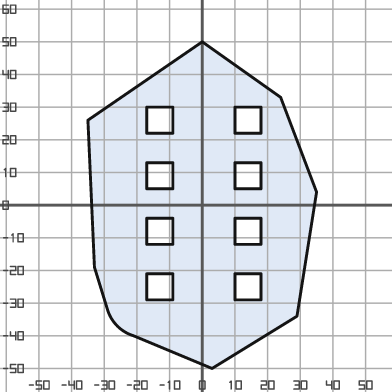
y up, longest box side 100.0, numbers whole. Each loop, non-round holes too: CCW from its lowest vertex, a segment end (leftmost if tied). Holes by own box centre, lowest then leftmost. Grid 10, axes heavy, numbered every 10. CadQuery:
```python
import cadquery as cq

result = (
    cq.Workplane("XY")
    .moveTo(3.0, -50.0)
    .lineTo(29.0, -34.0)
    .lineTo(35.0, 4.0)
    .lineTo(24.0, 33.0)
    .lineTo(0.0, 50.0)
    .lineTo(-35.0, 26.0)
    .lineTo(-33.0, -19.0)
    .lineTo(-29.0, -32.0)
    .threePointArc((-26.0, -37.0), (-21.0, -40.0))
    .close()
    .moveTo(-17.0, -29.0)
    .lineTo(-9.0, -29.0)
    .lineTo(-9.0, -21.0)
    .lineTo(-17.0, -21.0)
    .close()
    .moveTo(10.0, -29.0)
    .lineTo(18.0, -29.0)
    .lineTo(18.0, -21.0)
    .lineTo(10.0, -21.0)
    .close()
    .moveTo(-17.0, -12.0)
    .lineTo(-9.0, -12.0)
    .lineTo(-9.0, -4.0)
    .lineTo(-17.0, -4.0)
    .close()
    .moveTo(10.0, -12.0)
    .lineTo(18.0, -12.0)
    .lineTo(18.0, -4.0)
    .lineTo(10.0, -4.0)
    .close()
    .moveTo(-17.0, 5.0)
    .lineTo(-9.0, 5.0)
    .lineTo(-9.0, 13.0)
    .lineTo(-17.0, 13.0)
    .close()
    .moveTo(10.0, 5.0)
    .lineTo(18.0, 5.0)
    .lineTo(18.0, 13.0)
    .lineTo(10.0, 13.0)
    .close()
    .moveTo(-17.0, 22.0)
    .lineTo(-9.0, 22.0)
    .lineTo(-9.0, 30.0)
    .lineTo(-17.0, 30.0)
    .close()
    .moveTo(10.0, 22.0)
    .lineTo(18.0, 22.0)
    .lineTo(18.0, 30.0)
    .lineTo(10.0, 30.0)
    .close()
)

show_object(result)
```